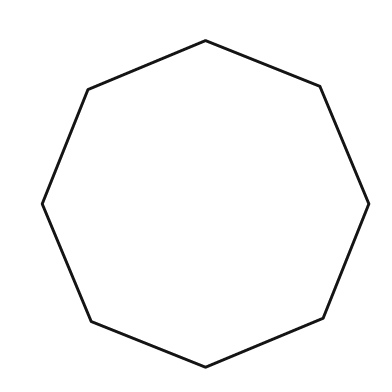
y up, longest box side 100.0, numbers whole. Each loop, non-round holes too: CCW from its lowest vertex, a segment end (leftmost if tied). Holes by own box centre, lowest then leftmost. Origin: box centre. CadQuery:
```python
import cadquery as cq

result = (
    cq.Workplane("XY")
    .moveTo(0.0, -50.0)
    .lineTo(36.0, -35.0)
    .lineTo(50.0, 0.0)
    .lineTo(35.0, 36.0)
    .lineTo(0.0, 50.0)
    .lineTo(-36.0, 35.0)
    .lineTo(-50.0, 0.0)
    .lineTo(-35.0, -36.0)
    .close()
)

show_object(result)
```